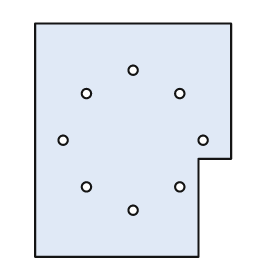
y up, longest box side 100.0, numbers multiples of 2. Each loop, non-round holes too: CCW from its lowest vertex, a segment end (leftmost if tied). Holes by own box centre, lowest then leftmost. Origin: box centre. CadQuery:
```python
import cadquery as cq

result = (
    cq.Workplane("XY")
    .moveTo(-42.0, -50.0)
    .lineTo(28.0, -50.0)
    .lineTo(28.0, -8.0)
    .lineTo(42.0, -8.0)
    .lineTo(42.0, 50.0)
    .lineTo(-42.0, 50.0)
    .close()
    .moveTo(0.0, -30.0)
    .circle(2.0)
    .moveTo(-20.0, -20.0)
    .circle(2.0)
    .moveTo(20.0, -20.0)
    .circle(2.0)
    .moveTo(-30.0, 0.0)
    .circle(2.0)
    .moveTo(30.0, 0.0)
    .circle(2.0)
    .moveTo(-20.0, 20.0)
    .circle(2.0)
    .moveTo(20.0, 20.0)
    .circle(2.0)
    .moveTo(0.0, 30.0)
    .circle(2.0)
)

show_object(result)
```